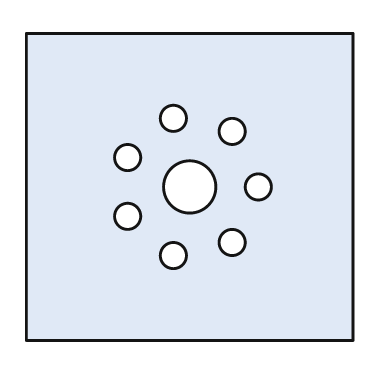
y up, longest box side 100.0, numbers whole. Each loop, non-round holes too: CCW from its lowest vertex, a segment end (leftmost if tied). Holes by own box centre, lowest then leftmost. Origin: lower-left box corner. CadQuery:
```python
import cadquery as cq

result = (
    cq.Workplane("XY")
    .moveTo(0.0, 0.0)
    .lineTo(100.0, 0.0)
    .lineTo(100.0, 94.0)
    .lineTo(0.0, 94.0)
    .close()
    .moveTo(45.0, 26.0)
    .circle(4.0)
    .moveTo(63.0, 30.0)
    .circle(4.0)
    .moveTo(31.0, 38.0)
    .circle(4.0)
    .moveTo(50.0, 47.0)
    .circle(8.0)
    .moveTo(71.0, 47.0)
    .circle(4.0)
    .moveTo(31.0, 56.0)
    .circle(4.0)
    .moveTo(63.0, 64.0)
    .circle(4.0)
    .moveTo(45.0, 68.0)
    .circle(4.0)
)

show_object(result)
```